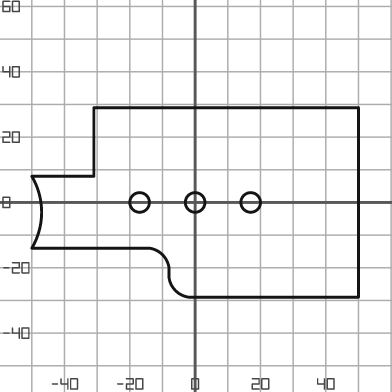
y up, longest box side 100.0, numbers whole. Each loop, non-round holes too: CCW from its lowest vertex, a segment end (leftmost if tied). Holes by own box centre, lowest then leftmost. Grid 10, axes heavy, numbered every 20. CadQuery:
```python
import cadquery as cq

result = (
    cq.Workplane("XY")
    .moveTo(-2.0, -29.0)
    .lineTo(50.0, -29.0)
    .lineTo(50.0, 29.0)
    .lineTo(-31.0, 29.0)
    .lineTo(-31.0, 8.0)
    .lineTo(-50.0, 8.0)
    .threePointArc((-47.0, -3.0), (-50.0, -14.0))
    .lineTo(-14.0, -14.0)
    .threePointArc((-10.0, -16.0), (-8.0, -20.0))
    .lineTo(-8.0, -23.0)
    .threePointArc((-6.0, -27.0), (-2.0, -29.0))
    .close()
    .moveTo(-17.0, 0.0)
    .circle(3.0)
    .moveTo(0.0, 0.0)
    .circle(3.0)
    .moveTo(17.0, 0.0)
    .circle(3.0)
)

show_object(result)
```